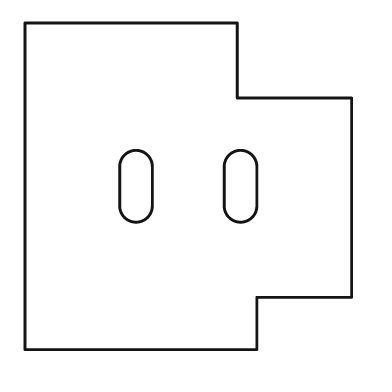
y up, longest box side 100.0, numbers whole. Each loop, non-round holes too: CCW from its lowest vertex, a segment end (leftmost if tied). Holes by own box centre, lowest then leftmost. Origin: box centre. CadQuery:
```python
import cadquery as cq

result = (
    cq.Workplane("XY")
    .moveTo(-50.0, -50.0)
    .lineTo(21.0, -50.0)
    .lineTo(21.0, -34.0)
    .lineTo(50.0, -34.0)
    .lineTo(50.0, 27.0)
    .lineTo(15.0, 27.0)
    .lineTo(15.0, 50.0)
    .lineTo(-50.0, 50.0)
    .close()
    .moveTo(-21.0, -6.0)
    .threePointArc((-16.0, -11.0), (-11.0, -6.0))
    .lineTo(-11.0, 6.0)
    .threePointArc((-16.0, 11.0), (-21.0, 6.0))
    .close()
    .moveTo(11.0, -6.0)
    .threePointArc((16.0, -11.0), (21.0, -6.0))
    .lineTo(21.0, 6.0)
    .threePointArc((16.0, 11.0), (11.0, 6.0))
    .close()
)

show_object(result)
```